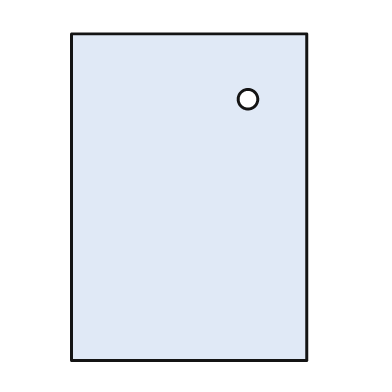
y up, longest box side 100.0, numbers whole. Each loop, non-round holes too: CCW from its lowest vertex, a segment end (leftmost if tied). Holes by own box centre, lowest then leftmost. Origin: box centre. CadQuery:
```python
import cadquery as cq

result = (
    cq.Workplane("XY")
    .moveTo(-36.0, -50.0)
    .lineTo(36.0, -50.0)
    .lineTo(36.0, 50.0)
    .lineTo(-36.0, 50.0)
    .close()
    .moveTo(18.0, 30.0)
    .circle(3.0)
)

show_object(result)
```